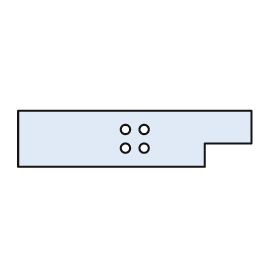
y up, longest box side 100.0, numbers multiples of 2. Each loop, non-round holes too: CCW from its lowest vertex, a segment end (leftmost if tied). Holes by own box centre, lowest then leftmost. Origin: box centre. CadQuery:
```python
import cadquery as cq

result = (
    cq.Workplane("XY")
    .moveTo(-50.0, -12.0)
    .lineTo(30.0, -12.0)
    .lineTo(30.0, -2.0)
    .lineTo(50.0, -2.0)
    .lineTo(50.0, 12.0)
    .lineTo(-50.0, 12.0)
    .close()
    .moveTo(-4.0, -4.0)
    .circle(2.0)
    .moveTo(4.0, -4.0)
    .circle(2.0)
    .moveTo(-4.0, 4.0)
    .circle(2.0)
    .moveTo(4.0, 4.0)
    .circle(2.0)
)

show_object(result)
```